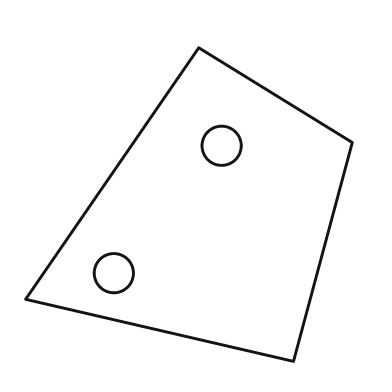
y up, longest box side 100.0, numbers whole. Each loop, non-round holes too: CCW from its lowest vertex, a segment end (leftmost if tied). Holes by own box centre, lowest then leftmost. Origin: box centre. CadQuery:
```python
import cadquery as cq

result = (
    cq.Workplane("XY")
    .moveTo(32.0, -48.0)
    .lineTo(50.0, 19.0)
    .lineTo(3.0, 48.0)
    .lineTo(-50.0, -29.0)
    .close()
    .moveTo(-23.0, -21.0)
    .circle(6.0)
    .moveTo(10.0, 18.0)
    .circle(6.0)
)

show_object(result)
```